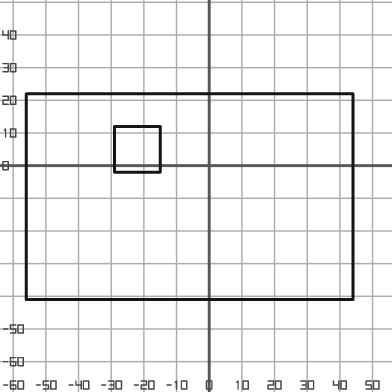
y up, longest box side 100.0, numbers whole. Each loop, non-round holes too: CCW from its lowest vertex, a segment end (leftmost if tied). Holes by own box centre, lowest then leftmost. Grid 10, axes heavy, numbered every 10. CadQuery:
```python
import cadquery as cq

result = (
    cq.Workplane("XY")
    .moveTo(-56.0, -41.0)
    .lineTo(44.0, -41.0)
    .lineTo(44.0, 22.0)
    .lineTo(-56.0, 22.0)
    .close()
    .moveTo(-29.0, -2.0)
    .lineTo(-15.0, -2.0)
    .lineTo(-15.0, 12.0)
    .lineTo(-29.0, 12.0)
    .close()
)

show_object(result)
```